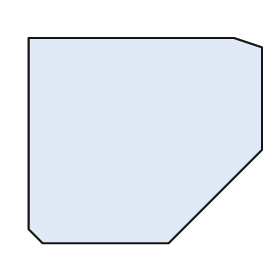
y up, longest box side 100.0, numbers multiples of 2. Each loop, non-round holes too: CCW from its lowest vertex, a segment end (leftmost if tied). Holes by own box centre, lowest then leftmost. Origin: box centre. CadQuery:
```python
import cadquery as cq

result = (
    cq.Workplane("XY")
    .moveTo(-44.0, -44.0)
    .lineTo(10.0, -44.0)
    .lineTo(50.0, -4.0)
    .lineTo(50.0, 40.0)
    .lineTo(38.0, 44.0)
    .lineTo(-50.0, 44.0)
    .lineTo(-50.0, -38.0)
    .close()
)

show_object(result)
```